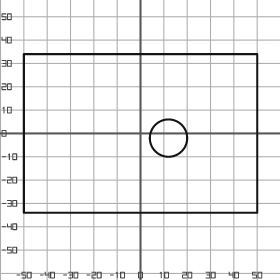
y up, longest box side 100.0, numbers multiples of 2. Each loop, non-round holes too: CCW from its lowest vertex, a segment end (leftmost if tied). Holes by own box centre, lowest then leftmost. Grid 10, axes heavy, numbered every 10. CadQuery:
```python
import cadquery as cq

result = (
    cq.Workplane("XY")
    .moveTo(-50.0, -34.0)
    .lineTo(50.0, -34.0)
    .lineTo(50.0, 34.0)
    .lineTo(-50.0, 34.0)
    .close()
    .moveTo(12.0, -2.0)
    .circle(8.0)
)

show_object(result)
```